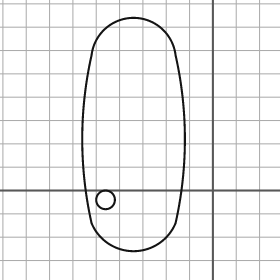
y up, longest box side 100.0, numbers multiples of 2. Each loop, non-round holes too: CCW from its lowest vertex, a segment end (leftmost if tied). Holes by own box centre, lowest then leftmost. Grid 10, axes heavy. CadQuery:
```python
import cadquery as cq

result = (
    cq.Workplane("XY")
    .moveTo(-52.0, -14.0)
    .threePointArc((-34.0, -26.0), (-16.0, -14.0))
    .threePointArc((-12.0, 22.0), (-16.0, 58.0))
    .threePointArc((-34.0, 74.0), (-52.0, 58.0))
    .threePointArc((-56.0, 22.0), (-52.0, -14.0))
    .close()
    .moveTo(-46.0, -4.0)
    .circle(4.0)
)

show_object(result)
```